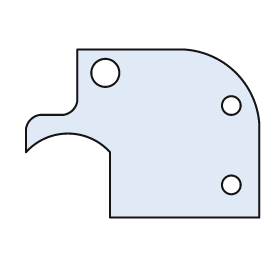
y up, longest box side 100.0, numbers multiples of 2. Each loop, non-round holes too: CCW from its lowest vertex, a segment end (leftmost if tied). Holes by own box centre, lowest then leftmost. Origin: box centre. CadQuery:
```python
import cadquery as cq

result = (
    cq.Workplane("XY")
    .moveTo(-14.0, -36.0)
    .lineTo(50.0, -36.0)
    .lineTo(50.0, 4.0)
    .threePointArc((40.0, 26.0), (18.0, 36.0))
    .lineTo(-28.0, 36.0)
    .lineTo(-28.0, 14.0)
    .threePointArc((-30.0, 10.0), (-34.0, 8.0))
    .lineTo(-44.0, 8.0)
    .threePointArc((-48.0, 6.0), (-50.0, 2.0))
    .lineTo(-50.0, -8.0)
    .threePointArc((-32.0, 0.0), (-14.0, -8.0))
    .close()
    .moveTo(38.0, -22.0)
    .circle(4.0)
    .moveTo(38.0, 12.0)
    .circle(4.0)
    .moveTo(-16.0, 26.0)
    .circle(6.0)
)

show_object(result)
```